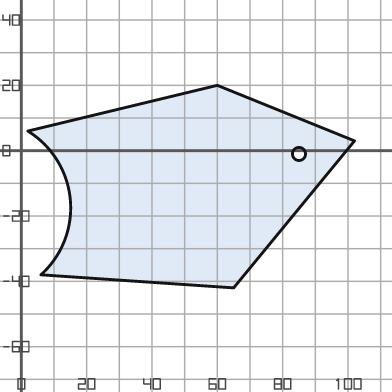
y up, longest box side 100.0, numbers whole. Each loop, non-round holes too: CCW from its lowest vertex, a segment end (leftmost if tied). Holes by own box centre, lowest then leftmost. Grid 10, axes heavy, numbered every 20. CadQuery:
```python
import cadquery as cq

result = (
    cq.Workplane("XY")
    .moveTo(65.0, -42.0)
    .lineTo(102.0, 3.0)
    .lineTo(60.0, 20.0)
    .lineTo(2.0, 6.0)
    .threePointArc((15.0, -15.0), (6.0, -38.0))
    .close()
    .moveTo(85.0, -1.0)
    .circle(2.0)
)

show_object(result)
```